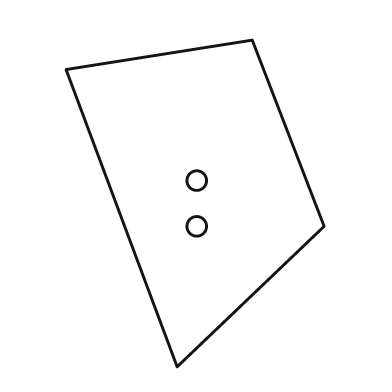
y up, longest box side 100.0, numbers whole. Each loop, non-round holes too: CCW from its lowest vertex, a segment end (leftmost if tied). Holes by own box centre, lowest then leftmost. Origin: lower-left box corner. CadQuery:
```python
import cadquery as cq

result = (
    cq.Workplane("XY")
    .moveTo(34.0, 0.0)
    .lineTo(79.0, 43.0)
    .lineTo(57.0, 100.0)
    .lineTo(0.0, 91.0)
    .close()
    .moveTo(40.0, 43.0)
    .circle(3.0)
    .moveTo(40.0, 57.0)
    .circle(3.0)
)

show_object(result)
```